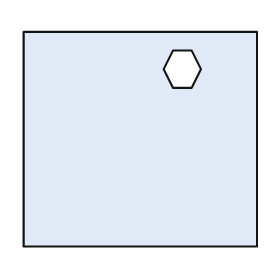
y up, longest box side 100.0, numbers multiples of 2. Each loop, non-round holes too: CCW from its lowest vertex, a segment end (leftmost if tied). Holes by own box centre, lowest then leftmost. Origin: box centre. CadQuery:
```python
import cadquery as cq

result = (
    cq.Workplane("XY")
    .moveTo(-50.0, -46.0)
    .lineTo(50.0, -46.0)
    .lineTo(50.0, 46.0)
    .lineTo(-50.0, 46.0)
    .close()
    .moveTo(14.0, 22.0)
    .lineTo(22.0, 22.0)
    .lineTo(26.0, 30.0)
    .lineTo(22.0, 38.0)
    .lineTo(14.0, 38.0)
    .lineTo(10.0, 30.0)
    .close()
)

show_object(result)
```